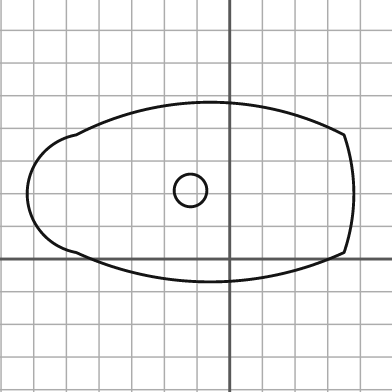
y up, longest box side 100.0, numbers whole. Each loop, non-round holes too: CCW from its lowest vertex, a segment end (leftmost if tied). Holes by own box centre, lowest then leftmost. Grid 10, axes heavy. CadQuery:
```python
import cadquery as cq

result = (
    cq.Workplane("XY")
    .moveTo(-47.0, 2.0)
    .threePointArc((-6.0, -7.0), (35.0, 2.0))
    .threePointArc((38.0, 20.0), (35.0, 38.0))
    .threePointArc((-6.0, 48.0), (-47.0, 38.0))
    .threePointArc((-62.0, 20.0), (-47.0, 2.0))
    .close()
    .moveTo(-12.0, 21.0)
    .circle(5.0)
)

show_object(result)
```